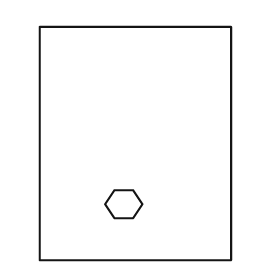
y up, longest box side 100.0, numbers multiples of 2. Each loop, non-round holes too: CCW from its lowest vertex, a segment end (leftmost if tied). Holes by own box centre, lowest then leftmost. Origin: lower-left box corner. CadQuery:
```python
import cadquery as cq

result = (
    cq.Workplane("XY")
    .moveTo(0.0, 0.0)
    .lineTo(82.0, 0.0)
    .lineTo(82.0, 100.0)
    .lineTo(0.0, 100.0)
    .close()
    .moveTo(32.0, 18.0)
    .lineTo(40.0, 18.0)
    .lineTo(44.0, 24.0)
    .lineTo(40.0, 30.0)
    .lineTo(32.0, 30.0)
    .lineTo(28.0, 24.0)
    .close()
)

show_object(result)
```